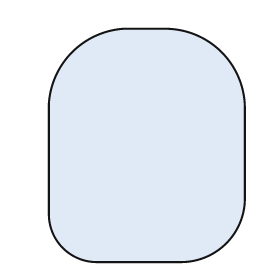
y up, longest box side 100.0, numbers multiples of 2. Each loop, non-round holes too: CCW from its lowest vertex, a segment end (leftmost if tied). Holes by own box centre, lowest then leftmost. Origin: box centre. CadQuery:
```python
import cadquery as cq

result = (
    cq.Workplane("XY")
    .moveTo(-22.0, -50.0)
    .lineTo(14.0, -50.0)
    .threePointArc((34.0, -42.0), (42.0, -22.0))
    .lineTo(42.0, 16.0)
    .threePointArc((32.0, 40.0), (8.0, 50.0))
    .lineTo(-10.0, 50.0)
    .threePointArc((-32.0, 40.0), (-42.0, 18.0))
    .lineTo(-42.0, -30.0)
    .threePointArc((-36.0, -44.0), (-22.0, -50.0))
    .close()
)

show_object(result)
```